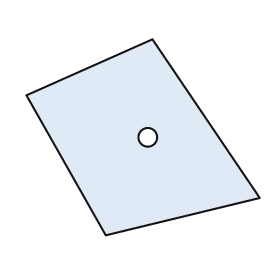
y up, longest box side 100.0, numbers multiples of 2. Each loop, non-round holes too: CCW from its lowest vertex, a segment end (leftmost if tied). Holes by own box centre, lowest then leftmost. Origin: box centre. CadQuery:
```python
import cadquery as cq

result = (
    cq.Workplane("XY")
    .moveTo(-16.0, -42.0)
    .lineTo(50.0, -26.0)
    .lineTo(4.0, 42.0)
    .lineTo(-50.0, 18.0)
    .close()
    .moveTo(2.0, 0.0)
    .circle(4.0)
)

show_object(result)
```